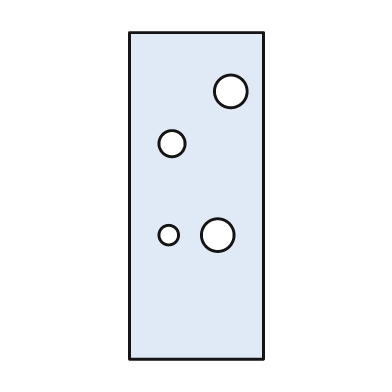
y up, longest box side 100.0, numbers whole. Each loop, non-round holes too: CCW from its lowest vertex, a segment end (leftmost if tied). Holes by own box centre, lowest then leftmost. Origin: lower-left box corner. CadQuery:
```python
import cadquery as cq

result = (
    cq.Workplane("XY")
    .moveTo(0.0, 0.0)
    .lineTo(41.0, 0.0)
    .lineTo(41.0, 100.0)
    .lineTo(0.0, 100.0)
    .close()
    .moveTo(12.0, 38.0)
    .circle(3.0)
    .moveTo(27.0, 38.0)
    .circle(5.0)
    .moveTo(13.0, 66.0)
    .circle(4.0)
    .moveTo(31.0, 82.0)
    .circle(5.0)
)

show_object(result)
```